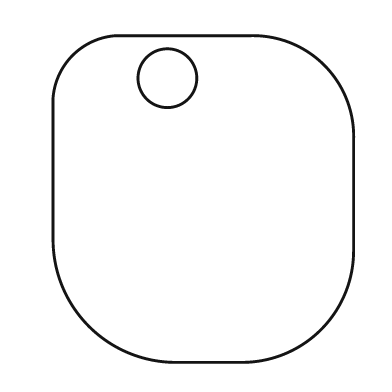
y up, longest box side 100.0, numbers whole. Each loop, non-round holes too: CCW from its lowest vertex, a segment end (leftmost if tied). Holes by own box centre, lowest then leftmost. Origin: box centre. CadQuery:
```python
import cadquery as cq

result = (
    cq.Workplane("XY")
    .moveTo(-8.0, -50.0)
    .lineTo(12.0, -50.0)
    .threePointArc((36.0, -40.0), (46.0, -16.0))
    .lineTo(46.0, 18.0)
    .threePointArc((37.0, 41.0), (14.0, 50.0))
    .lineTo(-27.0, 50.0)
    .threePointArc((-40.0, 44.0), (-46.0, 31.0))
    .lineTo(-46.0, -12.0)
    .threePointArc((-35.0, -39.0), (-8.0, -50.0))
    .close()
    .moveTo(-11.0, 37.0)
    .circle(9.0)
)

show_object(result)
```